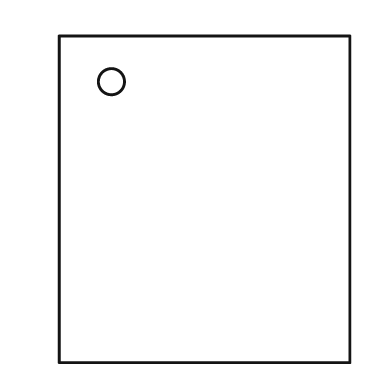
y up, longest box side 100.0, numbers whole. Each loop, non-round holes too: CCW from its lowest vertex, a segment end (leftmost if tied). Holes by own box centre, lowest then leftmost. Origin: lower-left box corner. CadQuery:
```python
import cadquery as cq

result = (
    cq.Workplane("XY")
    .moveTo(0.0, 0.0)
    .lineTo(89.0, 0.0)
    .lineTo(89.0, 100.0)
    .lineTo(0.0, 100.0)
    .close()
    .moveTo(16.0, 86.0)
    .circle(4.0)
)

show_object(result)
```